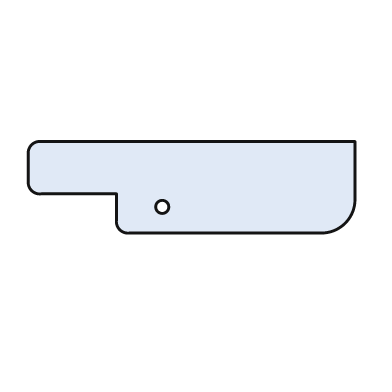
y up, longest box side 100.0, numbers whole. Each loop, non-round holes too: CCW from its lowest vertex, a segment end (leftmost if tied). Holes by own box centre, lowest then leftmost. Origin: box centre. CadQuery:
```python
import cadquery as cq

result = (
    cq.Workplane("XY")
    .moveTo(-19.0, -14.0)
    .lineTo(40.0, -14.0)
    .threePointArc((47.0, -11.0), (50.0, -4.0))
    .lineTo(50.0, 14.0)
    .lineTo(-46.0, 14.0)
    .threePointArc((-49.0, 13.0), (-50.0, 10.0))
    .lineTo(-50.0, 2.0)
    .threePointArc((-49.0, -1.0), (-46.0, -2.0))
    .lineTo(-23.0, -2.0)
    .lineTo(-23.0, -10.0)
    .threePointArc((-22.0, -13.0), (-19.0, -14.0))
    .close()
    .moveTo(-9.0, -6.0)
    .circle(2.0)
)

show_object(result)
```